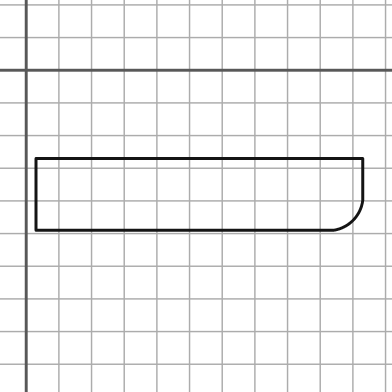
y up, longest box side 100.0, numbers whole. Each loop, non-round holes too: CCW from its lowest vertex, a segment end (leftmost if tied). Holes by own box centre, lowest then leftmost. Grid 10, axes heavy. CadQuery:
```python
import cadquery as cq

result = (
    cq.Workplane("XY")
    .moveTo(3.0, -49.0)
    .lineTo(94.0, -49.0)
    .threePointArc((100.0, -46.0), (103.0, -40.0))
    .lineTo(103.0, -27.0)
    .lineTo(3.0, -27.0)
    .close()
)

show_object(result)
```